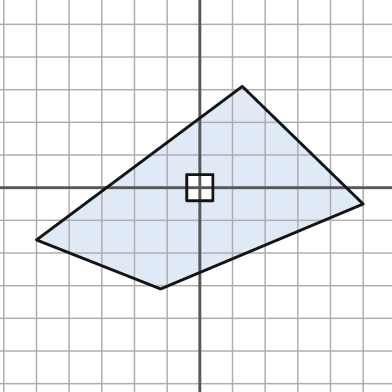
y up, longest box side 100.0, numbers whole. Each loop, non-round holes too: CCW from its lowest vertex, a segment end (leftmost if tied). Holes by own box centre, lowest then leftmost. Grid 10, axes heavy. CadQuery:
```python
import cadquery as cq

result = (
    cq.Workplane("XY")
    .moveTo(-12.0, -31.0)
    .lineTo(50.0, -5.0)
    .lineTo(13.0, 31.0)
    .lineTo(-50.0, -16.0)
    .close()
    .moveTo(-4.0, -4.0)
    .lineTo(4.0, -4.0)
    .lineTo(4.0, 4.0)
    .lineTo(-4.0, 4.0)
    .close()
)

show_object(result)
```